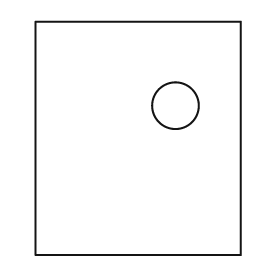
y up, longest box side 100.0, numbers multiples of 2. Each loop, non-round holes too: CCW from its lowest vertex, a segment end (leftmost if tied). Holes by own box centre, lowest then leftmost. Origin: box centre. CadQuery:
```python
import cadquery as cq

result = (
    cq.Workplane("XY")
    .moveTo(-44.0, -50.0)
    .lineTo(44.0, -50.0)
    .lineTo(44.0, 50.0)
    .lineTo(-44.0, 50.0)
    .close()
    .moveTo(16.0, 14.0)
    .circle(10.0)
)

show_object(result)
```